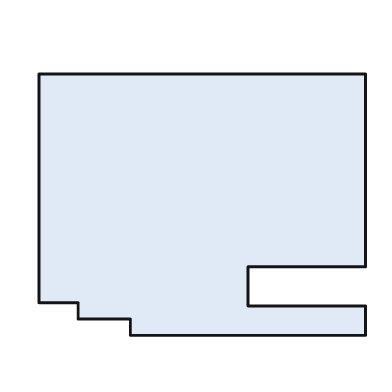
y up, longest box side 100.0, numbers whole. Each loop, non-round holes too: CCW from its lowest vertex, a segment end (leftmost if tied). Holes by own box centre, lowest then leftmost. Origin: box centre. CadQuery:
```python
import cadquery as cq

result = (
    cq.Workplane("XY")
    .moveTo(-22.0, -40.0)
    .lineTo(50.0, -40.0)
    .lineTo(50.0, -31.0)
    .lineTo(14.0, -31.0)
    .lineTo(14.0, -19.0)
    .lineTo(50.0, -19.0)
    .lineTo(50.0, 40.0)
    .lineTo(-50.0, 40.0)
    .lineTo(-50.0, -30.0)
    .lineTo(-38.0, -30.0)
    .lineTo(-38.0, -35.0)
    .lineTo(-22.0, -35.0)
    .close()
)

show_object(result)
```